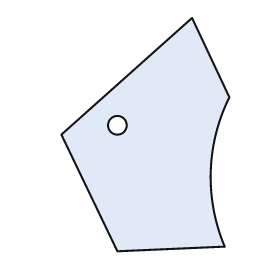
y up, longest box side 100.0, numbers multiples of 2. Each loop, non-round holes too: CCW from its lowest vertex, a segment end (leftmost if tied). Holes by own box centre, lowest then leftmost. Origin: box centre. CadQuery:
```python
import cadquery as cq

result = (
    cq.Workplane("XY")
    .moveTo(-12.0, -50.0)
    .lineTo(34.0, -48.0)
    .threePointArc((28.0, -16.0), (36.0, 16.0))
    .lineTo(20.0, 50.0)
    .lineTo(-36.0, 0.0)
    .close()
    .moveTo(-12.0, 4.0)
    .circle(4.0)
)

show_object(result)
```